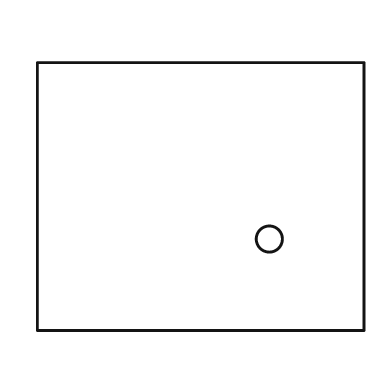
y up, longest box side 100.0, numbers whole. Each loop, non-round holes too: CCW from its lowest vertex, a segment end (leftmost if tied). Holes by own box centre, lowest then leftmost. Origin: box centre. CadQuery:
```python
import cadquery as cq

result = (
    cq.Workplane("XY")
    .moveTo(-50.0, -41.0)
    .lineTo(50.0, -41.0)
    .lineTo(50.0, 41.0)
    .lineTo(-50.0, 41.0)
    .close()
    .moveTo(21.0, -13.0)
    .circle(4.0)
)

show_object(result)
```